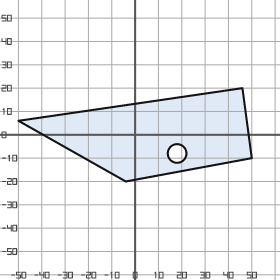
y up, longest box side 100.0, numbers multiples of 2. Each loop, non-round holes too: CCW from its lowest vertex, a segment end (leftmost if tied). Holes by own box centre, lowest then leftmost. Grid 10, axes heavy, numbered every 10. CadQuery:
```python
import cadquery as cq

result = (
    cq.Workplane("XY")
    .moveTo(-4.0, -20.0)
    .lineTo(50.0, -10.0)
    .lineTo(46.0, 20.0)
    .lineTo(-50.0, 6.0)
    .close()
    .moveTo(18.0, -8.0)
    .circle(4.0)
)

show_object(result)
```